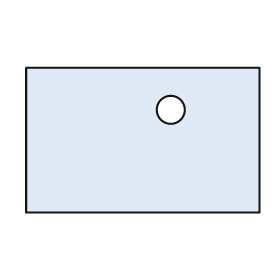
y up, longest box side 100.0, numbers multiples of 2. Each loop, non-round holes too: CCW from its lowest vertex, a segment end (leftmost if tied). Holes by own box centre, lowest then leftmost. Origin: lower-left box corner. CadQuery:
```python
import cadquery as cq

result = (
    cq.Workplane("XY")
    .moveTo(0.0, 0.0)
    .lineTo(100.0, 0.0)
    .lineTo(100.0, 62.0)
    .lineTo(0.0, 62.0)
    .close()
    .moveTo(62.0, 44.0)
    .circle(6.0)
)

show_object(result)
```